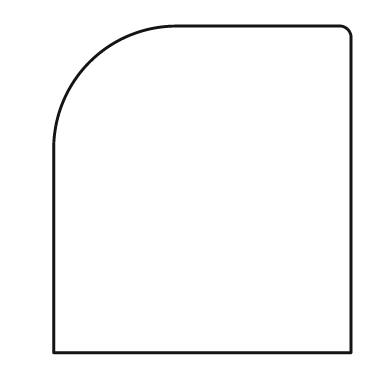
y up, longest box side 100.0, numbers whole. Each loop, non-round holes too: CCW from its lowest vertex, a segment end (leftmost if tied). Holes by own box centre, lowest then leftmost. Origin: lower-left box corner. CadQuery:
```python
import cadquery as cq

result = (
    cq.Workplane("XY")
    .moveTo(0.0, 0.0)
    .lineTo(91.0, 0.0)
    .lineTo(91.0, 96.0)
    .threePointArc((90.0, 99.0), (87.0, 100.0))
    .lineTo(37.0, 100.0)
    .threePointArc((11.0, 89.0), (0.0, 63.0))
    .close()
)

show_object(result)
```